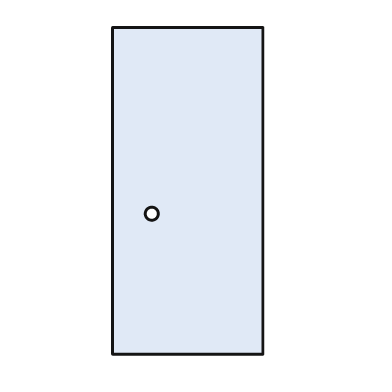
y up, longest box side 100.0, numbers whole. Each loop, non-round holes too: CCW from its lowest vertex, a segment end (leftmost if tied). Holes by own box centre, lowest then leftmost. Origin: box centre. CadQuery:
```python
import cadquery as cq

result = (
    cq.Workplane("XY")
    .moveTo(-23.0, -50.0)
    .lineTo(23.0, -50.0)
    .lineTo(23.0, 50.0)
    .lineTo(-23.0, 50.0)
    .close()
    .moveTo(-11.0, -7.0)
    .circle(2.0)
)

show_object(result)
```